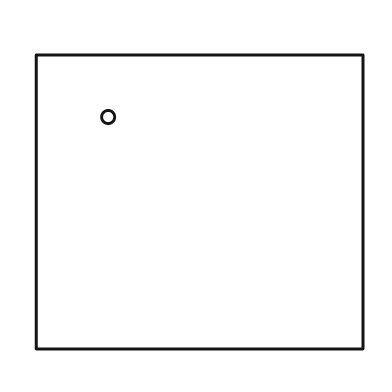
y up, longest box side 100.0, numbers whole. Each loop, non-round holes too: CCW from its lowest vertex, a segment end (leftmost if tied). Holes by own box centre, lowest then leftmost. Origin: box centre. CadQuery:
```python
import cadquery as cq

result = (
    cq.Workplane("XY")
    .moveTo(-50.0, -45.0)
    .lineTo(50.0, -45.0)
    .lineTo(50.0, 45.0)
    .lineTo(-50.0, 45.0)
    .close()
    .moveTo(-28.0, 26.0)
    .circle(2.0)
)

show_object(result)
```